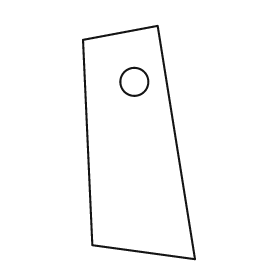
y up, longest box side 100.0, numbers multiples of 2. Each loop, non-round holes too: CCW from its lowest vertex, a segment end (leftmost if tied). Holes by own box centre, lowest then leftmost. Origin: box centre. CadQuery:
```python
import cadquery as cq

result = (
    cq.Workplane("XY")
    .moveTo(24.0, -50.0)
    .lineTo(8.0, 50.0)
    .lineTo(-24.0, 44.0)
    .lineTo(-20.0, -44.0)
    .close()
    .moveTo(-2.0, 26.0)
    .circle(6.0)
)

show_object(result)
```